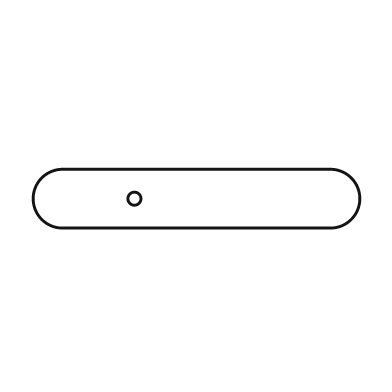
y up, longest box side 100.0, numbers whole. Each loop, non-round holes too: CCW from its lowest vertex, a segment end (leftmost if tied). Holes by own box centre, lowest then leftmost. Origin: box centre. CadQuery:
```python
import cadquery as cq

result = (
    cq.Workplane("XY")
    .moveTo(-41.0, -9.0)
    .lineTo(41.0, -9.0)
    .threePointArc((50.0, 0.0), (41.0, 9.0))
    .lineTo(-41.0, 9.0)
    .threePointArc((-50.0, 0.0), (-41.0, -9.0))
    .close()
    .moveTo(-19.0, 0.0)
    .circle(2.0)
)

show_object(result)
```